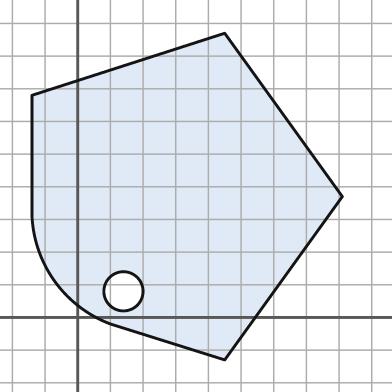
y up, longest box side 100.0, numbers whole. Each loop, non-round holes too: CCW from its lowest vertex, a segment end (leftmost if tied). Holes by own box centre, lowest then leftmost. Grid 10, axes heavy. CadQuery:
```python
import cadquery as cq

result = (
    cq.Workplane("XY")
    .moveTo(45.0, -13.0)
    .lineTo(81.0, 37.0)
    .lineTo(45.0, 87.0)
    .lineTo(-14.0, 68.0)
    .lineTo(-14.0, 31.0)
    .threePointArc((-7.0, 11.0), (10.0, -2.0))
    .close()
    .moveTo(14.0, 8.0)
    .circle(6.0)
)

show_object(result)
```